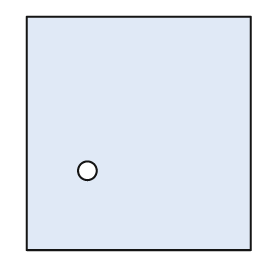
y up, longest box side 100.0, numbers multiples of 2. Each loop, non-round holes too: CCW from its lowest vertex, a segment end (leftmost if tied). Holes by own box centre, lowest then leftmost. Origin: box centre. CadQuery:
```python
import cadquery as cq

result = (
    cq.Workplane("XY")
    .moveTo(-48.0, -50.0)
    .lineTo(48.0, -50.0)
    .lineTo(48.0, 50.0)
    .lineTo(-48.0, 50.0)
    .close()
    .moveTo(-22.0, -16.0)
    .circle(4.0)
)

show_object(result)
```